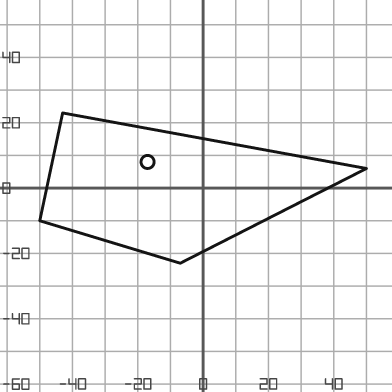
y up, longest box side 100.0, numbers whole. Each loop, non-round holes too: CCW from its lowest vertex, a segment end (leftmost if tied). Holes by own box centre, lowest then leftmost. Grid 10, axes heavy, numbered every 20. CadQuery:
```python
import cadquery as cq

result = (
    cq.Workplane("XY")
    .moveTo(-7.0, -23.0)
    .lineTo(50.0, 6.0)
    .lineTo(-43.0, 23.0)
    .lineTo(-50.0, -10.0)
    .close()
    .moveTo(-17.0, 8.0)
    .circle(2.0)
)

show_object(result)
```